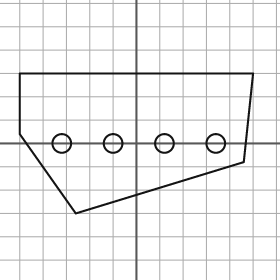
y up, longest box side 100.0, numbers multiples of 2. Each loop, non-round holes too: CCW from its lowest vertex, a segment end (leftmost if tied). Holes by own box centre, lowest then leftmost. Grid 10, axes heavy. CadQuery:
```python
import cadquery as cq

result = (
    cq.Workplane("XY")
    .moveTo(-26.0, -30.0)
    .lineTo(46.0, -8.0)
    .lineTo(50.0, 30.0)
    .lineTo(-50.0, 30.0)
    .lineTo(-50.0, 4.0)
    .close()
    .moveTo(-32.0, 0.0)
    .circle(4.0)
    .moveTo(-10.0, 0.0)
    .circle(4.0)
    .moveTo(12.0, 0.0)
    .circle(4.0)
    .moveTo(34.0, 0.0)
    .circle(4.0)
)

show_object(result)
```